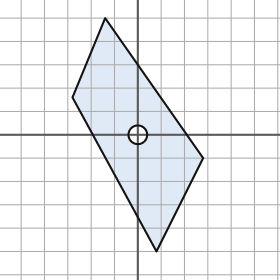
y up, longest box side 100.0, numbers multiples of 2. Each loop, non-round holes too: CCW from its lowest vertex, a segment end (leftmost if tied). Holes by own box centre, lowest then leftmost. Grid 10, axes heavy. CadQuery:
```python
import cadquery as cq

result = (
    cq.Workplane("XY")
    .moveTo(8.0, -50.0)
    .lineTo(28.0, -10.0)
    .lineTo(-14.0, 50.0)
    .lineTo(-28.0, 16.0)
    .close()
    .moveTo(0.0, 0.0)
    .circle(4.0)
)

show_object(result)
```